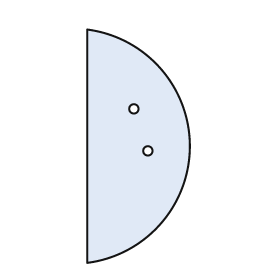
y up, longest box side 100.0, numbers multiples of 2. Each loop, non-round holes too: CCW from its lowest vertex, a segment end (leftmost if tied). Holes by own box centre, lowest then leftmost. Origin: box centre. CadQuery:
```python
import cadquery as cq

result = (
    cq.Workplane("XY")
    .moveTo(-22.0, -50.0)
    .threePointArc((22.0, 0.0), (-22.0, 50.0))
    .close()
    .moveTo(4.0, -2.0)
    .circle(2.0)
    .moveTo(-2.0, 16.0)
    .circle(2.0)
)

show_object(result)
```